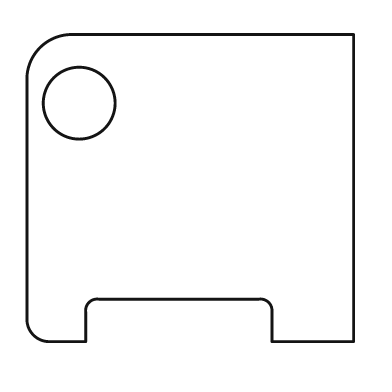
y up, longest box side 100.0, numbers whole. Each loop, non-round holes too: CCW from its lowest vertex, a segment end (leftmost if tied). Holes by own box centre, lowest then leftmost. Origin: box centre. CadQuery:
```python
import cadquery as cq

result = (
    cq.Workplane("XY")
    .moveTo(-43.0, -47.0)
    .lineTo(-32.0, -47.0)
    .lineTo(-32.0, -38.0)
    .threePointArc((-31.0, -35.0), (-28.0, -34.0))
    .lineTo(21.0, -34.0)
    .threePointArc((24.0, -35.0), (25.0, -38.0))
    .lineTo(25.0, -47.0)
    .lineTo(50.0, -47.0)
    .lineTo(50.0, 47.0)
    .lineTo(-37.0, 47.0)
    .threePointArc((-46.0, 43.0), (-50.0, 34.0))
    .lineTo(-50.0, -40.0)
    .threePointArc((-48.0, -45.0), (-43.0, -47.0))
    .close()
    .moveTo(-34.0, 26.0)
    .circle(11.0)
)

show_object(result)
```